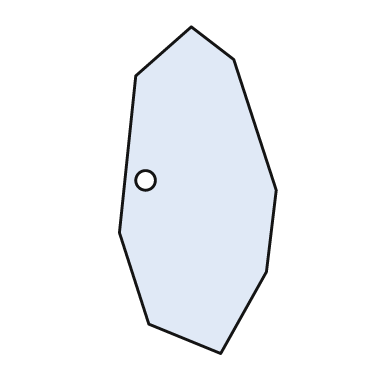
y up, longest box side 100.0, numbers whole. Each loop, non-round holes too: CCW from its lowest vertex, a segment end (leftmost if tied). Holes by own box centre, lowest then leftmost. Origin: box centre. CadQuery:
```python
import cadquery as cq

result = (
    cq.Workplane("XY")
    .moveTo(7.0, -50.0)
    .lineTo(21.0, -25.0)
    .lineTo(24.0, 0.0)
    .lineTo(11.0, 40.0)
    .lineTo(-2.0, 50.0)
    .lineTo(-19.0, 35.0)
    .lineTo(-24.0, -13.0)
    .lineTo(-15.0, -41.0)
    .close()
    .moveTo(-16.0, 3.0)
    .circle(3.0)
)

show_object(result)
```